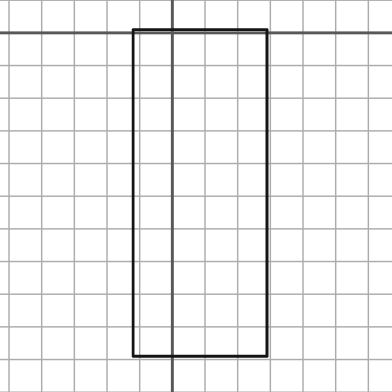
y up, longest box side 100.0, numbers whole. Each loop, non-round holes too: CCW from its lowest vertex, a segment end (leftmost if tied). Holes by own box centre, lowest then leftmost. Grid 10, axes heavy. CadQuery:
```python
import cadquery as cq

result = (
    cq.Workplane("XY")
    .moveTo(-12.0, -99.0)
    .lineTo(29.0, -99.0)
    .lineTo(29.0, 1.0)
    .lineTo(-12.0, 1.0)
    .close()
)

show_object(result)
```